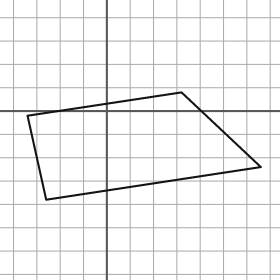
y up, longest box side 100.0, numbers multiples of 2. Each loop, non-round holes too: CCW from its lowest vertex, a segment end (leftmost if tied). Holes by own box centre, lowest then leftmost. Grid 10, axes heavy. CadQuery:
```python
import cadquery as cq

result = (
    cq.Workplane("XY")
    .moveTo(-26.0, -38.0)
    .lineTo(66.0, -24.0)
    .lineTo(32.0, 8.0)
    .lineTo(-34.0, -2.0)
    .close()
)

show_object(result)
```